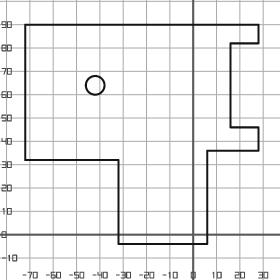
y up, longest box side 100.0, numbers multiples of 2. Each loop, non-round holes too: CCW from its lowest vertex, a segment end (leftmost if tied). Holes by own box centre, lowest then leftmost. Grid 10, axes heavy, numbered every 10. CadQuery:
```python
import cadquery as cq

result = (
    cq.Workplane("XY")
    .moveTo(-32.0, -4.0)
    .lineTo(6.0, -4.0)
    .lineTo(6.0, 36.0)
    .lineTo(28.0, 36.0)
    .lineTo(28.0, 46.0)
    .lineTo(16.0, 46.0)
    .lineTo(16.0, 82.0)
    .lineTo(28.0, 82.0)
    .lineTo(28.0, 90.0)
    .lineTo(-72.0, 90.0)
    .lineTo(-72.0, 32.0)
    .lineTo(-32.0, 32.0)
    .close()
    .moveTo(-42.0, 64.0)
    .circle(4.0)
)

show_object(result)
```